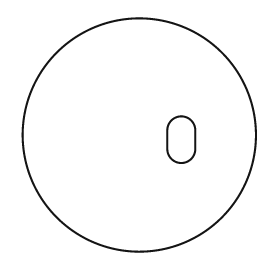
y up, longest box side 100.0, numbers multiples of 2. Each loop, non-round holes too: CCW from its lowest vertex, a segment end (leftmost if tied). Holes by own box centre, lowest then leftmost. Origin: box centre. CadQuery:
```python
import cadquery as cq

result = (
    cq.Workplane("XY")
    .moveTo(0.0, 0.0)
    .circle(50.0)
    .moveTo(12.0, -6.0)
    .threePointArc((18.0, -12.0), (24.0, -6.0))
    .lineTo(24.0, 2.0)
    .threePointArc((18.0, 8.0), (12.0, 2.0))
    .close()
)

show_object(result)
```